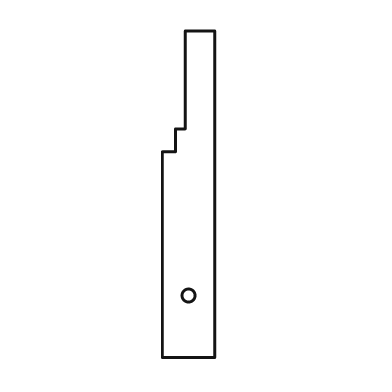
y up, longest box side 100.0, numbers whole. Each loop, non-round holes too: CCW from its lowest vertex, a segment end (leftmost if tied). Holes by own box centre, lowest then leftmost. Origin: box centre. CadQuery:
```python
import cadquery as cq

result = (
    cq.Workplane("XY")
    .moveTo(-8.0, -50.0)
    .lineTo(8.0, -50.0)
    .lineTo(8.0, 50.0)
    .lineTo(-1.0, 50.0)
    .lineTo(-1.0, 20.0)
    .lineTo(-4.0, 20.0)
    .lineTo(-4.0, 13.0)
    .lineTo(-8.0, 13.0)
    .close()
    .moveTo(0.0, -31.0)
    .circle(2.0)
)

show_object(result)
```